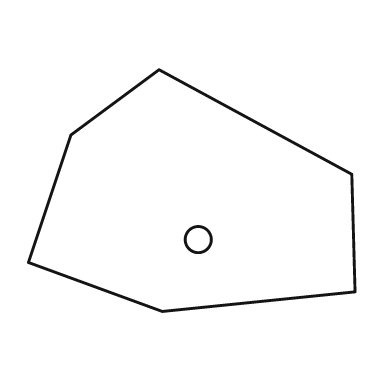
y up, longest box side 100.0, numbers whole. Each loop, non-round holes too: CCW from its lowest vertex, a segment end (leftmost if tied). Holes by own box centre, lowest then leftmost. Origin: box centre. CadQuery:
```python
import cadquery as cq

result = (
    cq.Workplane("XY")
    .moveTo(-9.0, -37.0)
    .lineTo(50.0, -31.0)
    .lineTo(49.0, 5.0)
    .lineTo(-10.0, 37.0)
    .lineTo(-37.0, 17.0)
    .lineTo(-50.0, -22.0)
    .close()
    .moveTo(2.0, -15.0)
    .circle(4.0)
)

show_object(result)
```